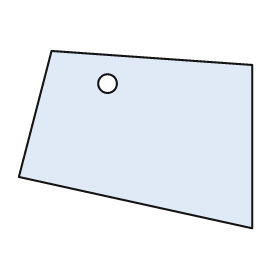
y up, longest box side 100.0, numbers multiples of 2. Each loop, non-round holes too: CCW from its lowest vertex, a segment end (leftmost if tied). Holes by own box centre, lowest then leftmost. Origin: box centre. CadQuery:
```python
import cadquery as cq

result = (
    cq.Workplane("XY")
    .moveTo(50.0, -38.0)
    .lineTo(50.0, 32.0)
    .lineTo(-36.0, 38.0)
    .lineTo(-50.0, -16.0)
    .close()
    .moveTo(-12.0, 24.0)
    .circle(4.0)
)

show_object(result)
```